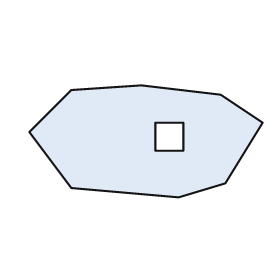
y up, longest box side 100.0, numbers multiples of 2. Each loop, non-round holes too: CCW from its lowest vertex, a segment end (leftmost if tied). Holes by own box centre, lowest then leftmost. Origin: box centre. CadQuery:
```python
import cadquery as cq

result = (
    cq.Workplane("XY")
    .moveTo(14.0, -24.0)
    .lineTo(34.0, -18.0)
    .lineTo(50.0, 8.0)
    .lineTo(32.0, 20.0)
    .lineTo(-2.0, 24.0)
    .lineTo(-32.0, 22.0)
    .lineTo(-50.0, 4.0)
    .lineTo(-32.0, -20.0)
    .close()
    .moveTo(4.0, -4.0)
    .lineTo(16.0, -4.0)
    .lineTo(16.0, 8.0)
    .lineTo(4.0, 8.0)
    .close()
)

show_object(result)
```